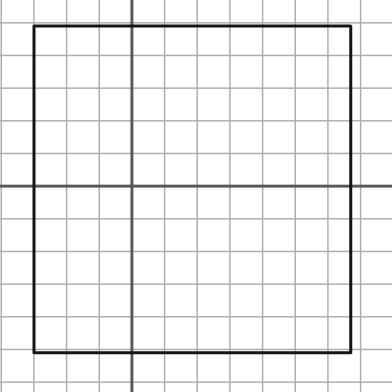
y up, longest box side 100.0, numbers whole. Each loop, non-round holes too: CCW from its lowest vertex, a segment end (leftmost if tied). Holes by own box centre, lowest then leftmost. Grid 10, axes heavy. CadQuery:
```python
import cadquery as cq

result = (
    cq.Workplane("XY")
    .moveTo(-30.0, -51.0)
    .lineTo(67.0, -51.0)
    .lineTo(67.0, 49.0)
    .lineTo(-30.0, 49.0)
    .close()
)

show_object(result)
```